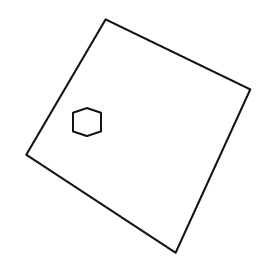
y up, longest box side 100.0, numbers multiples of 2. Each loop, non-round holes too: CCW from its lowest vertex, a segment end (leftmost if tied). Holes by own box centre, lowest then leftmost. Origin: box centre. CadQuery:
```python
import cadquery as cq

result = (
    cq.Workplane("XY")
    .moveTo(16.0, -50.0)
    .lineTo(48.0, 20.0)
    .lineTo(-14.0, 50.0)
    .lineTo(-48.0, -8.0)
    .close()
    .moveTo(-22.0, 0.0)
    .lineTo(-16.0, 2.0)
    .lineTo(-16.0, 10.0)
    .lineTo(-22.0, 12.0)
    .lineTo(-28.0, 10.0)
    .lineTo(-28.0, 2.0)
    .close()
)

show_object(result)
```